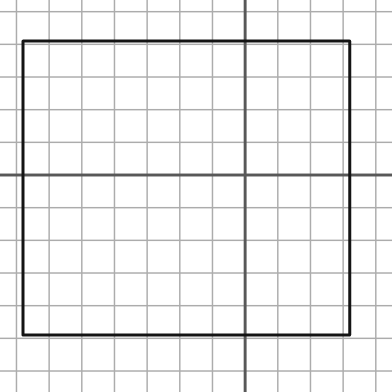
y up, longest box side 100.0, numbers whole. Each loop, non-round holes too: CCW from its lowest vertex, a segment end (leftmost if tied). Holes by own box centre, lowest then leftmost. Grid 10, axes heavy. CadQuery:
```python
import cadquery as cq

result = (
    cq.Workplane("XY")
    .moveTo(-68.0, -49.0)
    .lineTo(32.0, -49.0)
    .lineTo(32.0, 41.0)
    .lineTo(-68.0, 41.0)
    .close()
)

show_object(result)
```